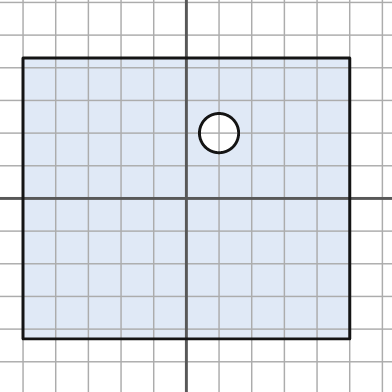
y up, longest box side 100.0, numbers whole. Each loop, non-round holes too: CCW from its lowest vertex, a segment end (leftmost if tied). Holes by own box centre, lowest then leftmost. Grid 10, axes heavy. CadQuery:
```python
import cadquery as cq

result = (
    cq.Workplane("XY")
    .moveTo(-50.0, -43.0)
    .lineTo(50.0, -43.0)
    .lineTo(50.0, 43.0)
    .lineTo(-50.0, 43.0)
    .close()
    .moveTo(10.0, 20.0)
    .circle(6.0)
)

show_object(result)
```